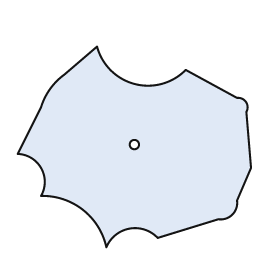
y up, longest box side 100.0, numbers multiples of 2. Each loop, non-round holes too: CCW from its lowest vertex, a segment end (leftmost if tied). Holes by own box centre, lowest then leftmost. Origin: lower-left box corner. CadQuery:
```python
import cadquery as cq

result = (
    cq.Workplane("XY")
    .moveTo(38.0, 0.0)
    .threePointArc((48.0, 8.0), (60.0, 4.0))
    .lineTo(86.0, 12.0)
    .threePointArc((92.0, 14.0), (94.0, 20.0))
    .lineTo(100.0, 34.0)
    .lineTo(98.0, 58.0)
    .threePointArc((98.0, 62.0), (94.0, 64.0))
    .lineTo(72.0, 76.0)
    .threePointArc((50.0, 70.0), (34.0, 86.0))
    .lineTo(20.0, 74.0)
    .threePointArc((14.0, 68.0), (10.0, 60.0))
    .lineTo(0.0, 40.0)
    .threePointArc((10.0, 34.0), (10.0, 22.0))
    .threePointArc((28.0, 16.0), (38.0, 0.0))
    .close()
    .moveTo(50.0, 44.0)
    .circle(2.0)
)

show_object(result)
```